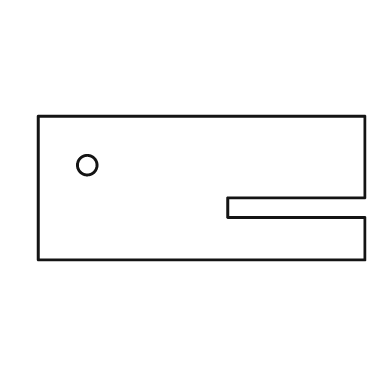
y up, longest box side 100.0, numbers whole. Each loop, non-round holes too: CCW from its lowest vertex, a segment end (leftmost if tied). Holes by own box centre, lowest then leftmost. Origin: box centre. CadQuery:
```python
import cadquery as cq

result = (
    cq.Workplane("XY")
    .moveTo(-50.0, -22.0)
    .lineTo(50.0, -22.0)
    .lineTo(50.0, -9.0)
    .lineTo(8.0, -9.0)
    .lineTo(8.0, -3.0)
    .lineTo(50.0, -3.0)
    .lineTo(50.0, 22.0)
    .lineTo(-50.0, 22.0)
    .close()
    .moveTo(-35.0, 7.0)
    .circle(3.0)
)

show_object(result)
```